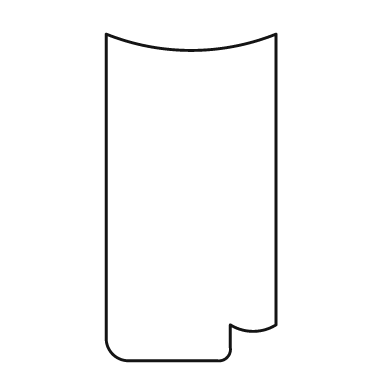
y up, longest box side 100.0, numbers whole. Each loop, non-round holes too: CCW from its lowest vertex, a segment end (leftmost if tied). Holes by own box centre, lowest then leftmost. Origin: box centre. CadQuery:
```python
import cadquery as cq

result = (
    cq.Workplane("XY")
    .moveTo(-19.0, -50.0)
    .lineTo(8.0, -50.0)
    .threePointArc((11.0, -49.0), (12.0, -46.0))
    .lineTo(12.0, -39.0)
    .threePointArc((19.0, -41.0), (26.0, -39.0))
    .lineTo(26.0, 50.0)
    .threePointArc((0.0, 45.0), (-26.0, 50.0))
    .lineTo(-26.0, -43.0)
    .threePointArc((-24.0, -48.0), (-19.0, -50.0))
    .close()
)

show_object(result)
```